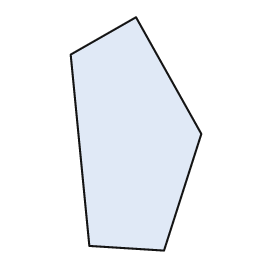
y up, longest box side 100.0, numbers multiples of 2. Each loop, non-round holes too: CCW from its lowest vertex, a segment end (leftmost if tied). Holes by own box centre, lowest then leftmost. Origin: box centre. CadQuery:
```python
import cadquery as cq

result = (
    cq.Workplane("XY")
    .moveTo(12.0, -50.0)
    .lineTo(28.0, 0.0)
    .lineTo(0.0, 50.0)
    .lineTo(-28.0, 34.0)
    .lineTo(-20.0, -48.0)
    .close()
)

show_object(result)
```